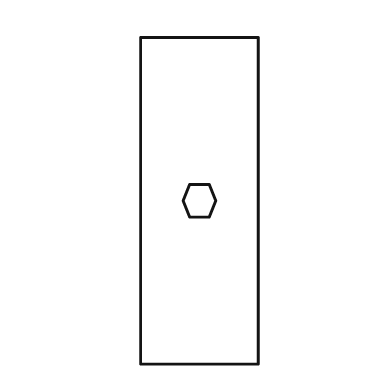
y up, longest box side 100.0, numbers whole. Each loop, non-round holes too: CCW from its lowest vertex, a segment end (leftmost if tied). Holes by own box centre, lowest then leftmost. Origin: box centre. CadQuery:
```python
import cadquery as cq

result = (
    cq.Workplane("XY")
    .moveTo(-18.0, -50.0)
    .lineTo(18.0, -50.0)
    .lineTo(18.0, 50.0)
    .lineTo(-18.0, 50.0)
    .close()
    .moveTo(-3.0, -5.0)
    .lineTo(3.0, -5.0)
    .lineTo(5.0, 0.0)
    .lineTo(3.0, 5.0)
    .lineTo(-3.0, 5.0)
    .lineTo(-5.0, 0.0)
    .close()
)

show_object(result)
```